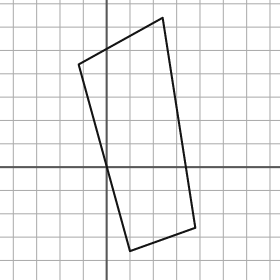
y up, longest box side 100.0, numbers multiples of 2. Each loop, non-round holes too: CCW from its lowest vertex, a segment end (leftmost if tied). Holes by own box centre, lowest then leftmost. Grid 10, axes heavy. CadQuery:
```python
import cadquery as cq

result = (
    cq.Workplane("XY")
    .moveTo(10.0, -36.0)
    .lineTo(38.0, -26.0)
    .lineTo(24.0, 64.0)
    .lineTo(-12.0, 44.0)
    .close()
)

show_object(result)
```